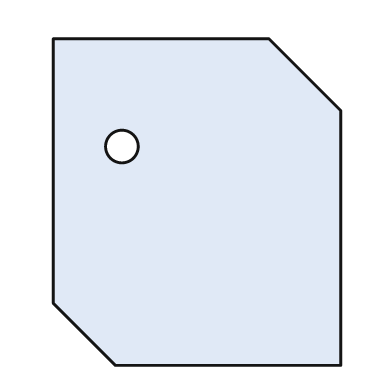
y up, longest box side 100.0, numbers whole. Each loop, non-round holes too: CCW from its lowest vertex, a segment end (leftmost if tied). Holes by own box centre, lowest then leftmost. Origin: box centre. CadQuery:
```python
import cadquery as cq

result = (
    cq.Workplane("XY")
    .moveTo(-25.0, -50.0)
    .lineTo(44.0, -50.0)
    .lineTo(44.0, 28.0)
    .lineTo(22.0, 50.0)
    .lineTo(-44.0, 50.0)
    .lineTo(-44.0, -31.0)
    .close()
    .moveTo(-23.0, 17.0)
    .circle(5.0)
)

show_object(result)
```